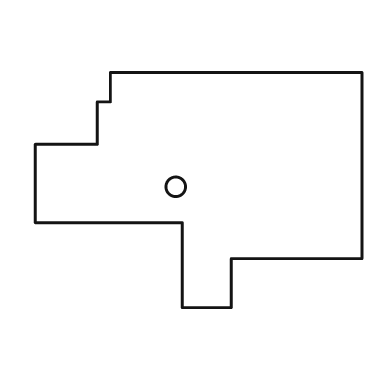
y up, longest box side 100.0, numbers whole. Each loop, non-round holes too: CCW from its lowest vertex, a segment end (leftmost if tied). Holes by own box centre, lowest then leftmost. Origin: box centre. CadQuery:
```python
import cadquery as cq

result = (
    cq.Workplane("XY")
    .moveTo(-5.0, -36.0)
    .lineTo(10.0, -36.0)
    .lineTo(10.0, -21.0)
    .lineTo(50.0, -21.0)
    .lineTo(50.0, 36.0)
    .lineTo(-27.0, 36.0)
    .lineTo(-27.0, 27.0)
    .lineTo(-31.0, 27.0)
    .lineTo(-31.0, 14.0)
    .lineTo(-50.0, 14.0)
    .lineTo(-50.0, -10.0)
    .lineTo(-5.0, -10.0)
    .close()
    .moveTo(-7.0, 1.0)
    .circle(3.0)
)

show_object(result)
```